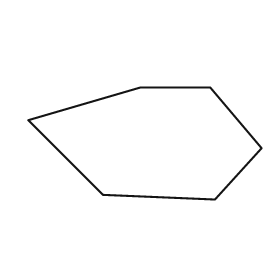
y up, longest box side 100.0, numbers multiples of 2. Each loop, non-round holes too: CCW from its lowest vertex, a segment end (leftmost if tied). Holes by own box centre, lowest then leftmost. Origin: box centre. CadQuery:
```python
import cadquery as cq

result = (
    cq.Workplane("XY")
    .moveTo(30.0, -24.0)
    .lineTo(50.0, -2.0)
    .lineTo(28.0, 24.0)
    .lineTo(-2.0, 24.0)
    .lineTo(-50.0, 10.0)
    .lineTo(-18.0, -22.0)
    .close()
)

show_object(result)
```